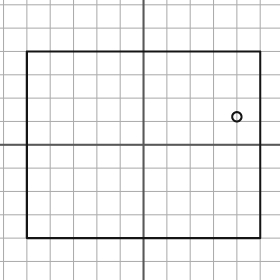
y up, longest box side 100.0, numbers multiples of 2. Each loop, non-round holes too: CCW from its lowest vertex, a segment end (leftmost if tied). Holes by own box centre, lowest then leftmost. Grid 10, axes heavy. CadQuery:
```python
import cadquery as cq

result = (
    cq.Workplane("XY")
    .moveTo(-50.0, -40.0)
    .lineTo(50.0, -40.0)
    .lineTo(50.0, 40.0)
    .lineTo(-50.0, 40.0)
    .close()
    .moveTo(40.0, 12.0)
    .circle(2.0)
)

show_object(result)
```